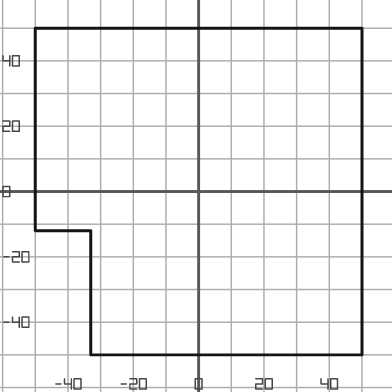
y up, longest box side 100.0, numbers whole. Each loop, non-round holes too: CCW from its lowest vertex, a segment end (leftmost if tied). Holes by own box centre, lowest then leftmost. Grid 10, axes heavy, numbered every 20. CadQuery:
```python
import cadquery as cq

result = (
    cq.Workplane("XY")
    .moveTo(-33.0, -50.0)
    .lineTo(50.0, -50.0)
    .lineTo(50.0, 50.0)
    .lineTo(-50.0, 50.0)
    .lineTo(-50.0, -12.0)
    .lineTo(-33.0, -12.0)
    .close()
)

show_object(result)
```